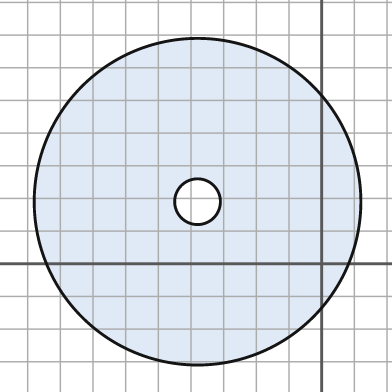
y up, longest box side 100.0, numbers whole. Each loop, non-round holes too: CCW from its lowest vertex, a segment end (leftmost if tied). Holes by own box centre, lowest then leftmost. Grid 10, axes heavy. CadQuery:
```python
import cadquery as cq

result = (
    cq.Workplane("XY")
    .moveTo(-38.0, 19.0)
    .circle(50.0)
    .moveTo(-38.0, 19.0)
    .circle(7.0)
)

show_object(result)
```